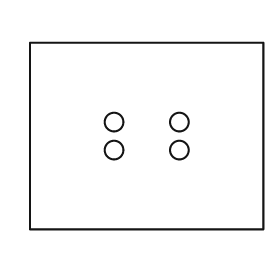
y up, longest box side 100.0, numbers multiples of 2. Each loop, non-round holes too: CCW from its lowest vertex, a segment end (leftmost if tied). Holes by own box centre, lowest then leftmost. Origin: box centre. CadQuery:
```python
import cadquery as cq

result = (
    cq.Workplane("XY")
    .moveTo(-50.0, -40.0)
    .lineTo(50.0, -40.0)
    .lineTo(50.0, 40.0)
    .lineTo(-50.0, 40.0)
    .close()
    .moveTo(-14.0, -6.0)
    .circle(4.0)
    .moveTo(14.0, -6.0)
    .circle(4.0)
    .moveTo(-14.0, 6.0)
    .circle(4.0)
    .moveTo(14.0, 6.0)
    .circle(4.0)
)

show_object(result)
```